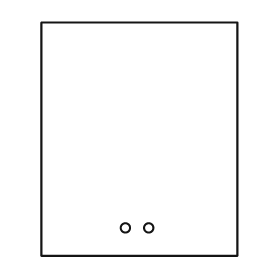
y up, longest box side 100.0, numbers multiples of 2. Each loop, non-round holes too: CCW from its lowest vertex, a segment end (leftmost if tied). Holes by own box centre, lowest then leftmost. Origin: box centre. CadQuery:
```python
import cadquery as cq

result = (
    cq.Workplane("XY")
    .moveTo(-42.0, -50.0)
    .lineTo(42.0, -50.0)
    .lineTo(42.0, 50.0)
    .lineTo(-42.0, 50.0)
    .close()
    .moveTo(-6.0, -38.0)
    .circle(2.0)
    .moveTo(4.0, -38.0)
    .circle(2.0)
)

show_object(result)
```